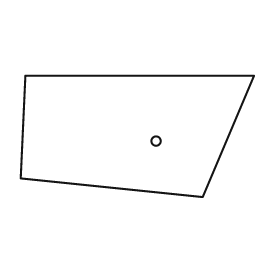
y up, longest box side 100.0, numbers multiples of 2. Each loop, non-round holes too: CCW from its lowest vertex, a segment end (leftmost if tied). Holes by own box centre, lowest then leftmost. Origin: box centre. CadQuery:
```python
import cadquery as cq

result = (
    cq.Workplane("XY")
    .moveTo(28.0, -26.0)
    .lineTo(50.0, 26.0)
    .lineTo(-48.0, 26.0)
    .lineTo(-50.0, -18.0)
    .close()
    .moveTo(8.0, -2.0)
    .circle(2.0)
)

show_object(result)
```